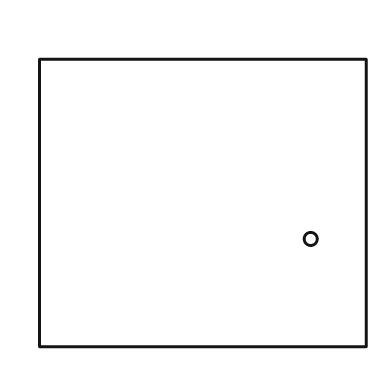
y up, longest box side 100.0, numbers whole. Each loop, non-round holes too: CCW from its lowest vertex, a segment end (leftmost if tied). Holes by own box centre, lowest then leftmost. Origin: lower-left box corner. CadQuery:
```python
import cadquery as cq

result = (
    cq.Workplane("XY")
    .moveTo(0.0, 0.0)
    .lineTo(100.0, 0.0)
    .lineTo(100.0, 88.0)
    .lineTo(0.0, 88.0)
    .close()
    .moveTo(83.0, 33.0)
    .circle(2.0)
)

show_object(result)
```